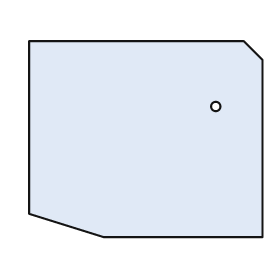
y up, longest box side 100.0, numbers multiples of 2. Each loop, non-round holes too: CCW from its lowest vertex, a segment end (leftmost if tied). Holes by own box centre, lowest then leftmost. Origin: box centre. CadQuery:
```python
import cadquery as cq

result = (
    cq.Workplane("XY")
    .moveTo(-18.0, -42.0)
    .lineTo(50.0, -42.0)
    .lineTo(50.0, 34.0)
    .lineTo(42.0, 42.0)
    .lineTo(-50.0, 42.0)
    .lineTo(-50.0, -32.0)
    .close()
    .moveTo(30.0, 14.0)
    .circle(2.0)
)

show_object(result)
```